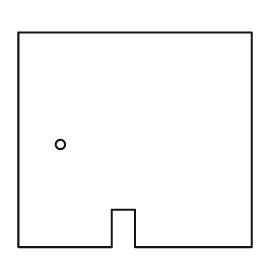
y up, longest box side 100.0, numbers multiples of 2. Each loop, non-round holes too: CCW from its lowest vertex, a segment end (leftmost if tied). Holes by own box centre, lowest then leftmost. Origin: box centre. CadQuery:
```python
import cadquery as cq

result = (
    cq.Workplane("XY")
    .moveTo(-50.0, -46.0)
    .lineTo(-10.0, -46.0)
    .lineTo(-10.0, -30.0)
    .lineTo(0.0, -30.0)
    .lineTo(0.0, -46.0)
    .lineTo(50.0, -46.0)
    .lineTo(50.0, 46.0)
    .lineTo(-50.0, 46.0)
    .close()
    .moveTo(-32.0, -2.0)
    .circle(2.0)
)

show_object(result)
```